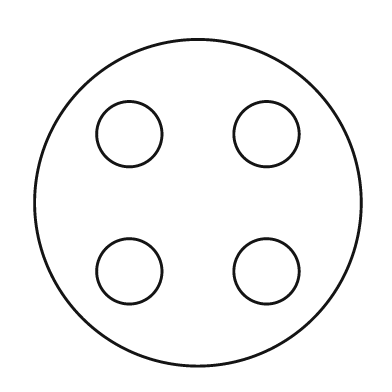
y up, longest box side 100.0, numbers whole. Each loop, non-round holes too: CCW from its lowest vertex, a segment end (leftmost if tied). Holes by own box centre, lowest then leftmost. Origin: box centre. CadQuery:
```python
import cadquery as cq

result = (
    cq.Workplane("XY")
    .moveTo(0.0, 0.0)
    .circle(50.0)
    .moveTo(-21.0, -21.0)
    .circle(10.0)
    .moveTo(21.0, -21.0)
    .circle(10.0)
    .moveTo(-21.0, 21.0)
    .circle(10.0)
    .moveTo(21.0, 21.0)
    .circle(10.0)
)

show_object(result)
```